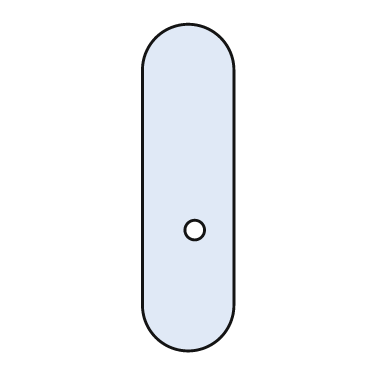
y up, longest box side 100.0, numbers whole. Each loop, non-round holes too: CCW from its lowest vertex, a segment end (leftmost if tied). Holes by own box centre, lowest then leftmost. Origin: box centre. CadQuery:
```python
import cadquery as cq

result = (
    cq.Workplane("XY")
    .moveTo(-14.0, -36.0)
    .threePointArc((0.0, -50.0), (14.0, -36.0))
    .lineTo(14.0, 36.0)
    .threePointArc((0.0, 50.0), (-14.0, 36.0))
    .close()
    .moveTo(2.0, -13.0)
    .circle(3.0)
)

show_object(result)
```